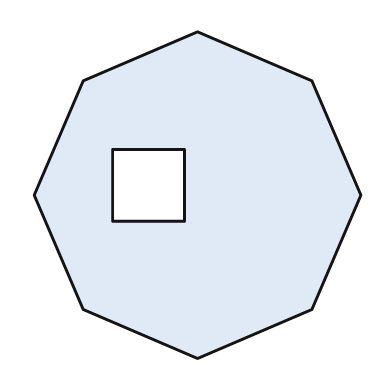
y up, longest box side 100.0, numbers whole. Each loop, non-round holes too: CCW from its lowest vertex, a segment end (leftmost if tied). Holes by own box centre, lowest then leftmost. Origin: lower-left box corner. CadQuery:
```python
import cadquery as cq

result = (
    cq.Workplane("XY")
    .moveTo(50.0, 0.0)
    .lineTo(85.0, 15.0)
    .lineTo(100.0, 50.0)
    .lineTo(85.0, 85.0)
    .lineTo(50.0, 100.0)
    .lineTo(15.0, 85.0)
    .lineTo(0.0, 50.0)
    .lineTo(15.0, 15.0)
    .close()
    .moveTo(24.0, 42.0)
    .lineTo(46.0, 42.0)
    .lineTo(46.0, 64.0)
    .lineTo(24.0, 64.0)
    .close()
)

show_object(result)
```